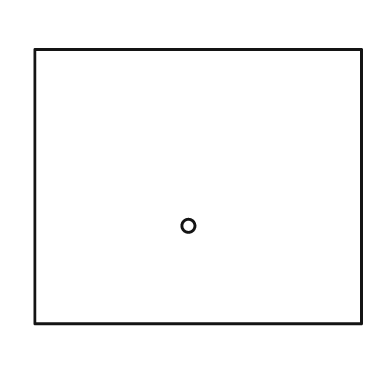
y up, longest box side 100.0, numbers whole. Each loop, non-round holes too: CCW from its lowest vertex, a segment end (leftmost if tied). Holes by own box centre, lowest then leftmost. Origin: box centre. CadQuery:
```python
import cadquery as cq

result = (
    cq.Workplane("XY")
    .moveTo(-50.0, -42.0)
    .lineTo(50.0, -42.0)
    .lineTo(50.0, 42.0)
    .lineTo(-50.0, 42.0)
    .close()
    .moveTo(-3.0, -12.0)
    .circle(2.0)
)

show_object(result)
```